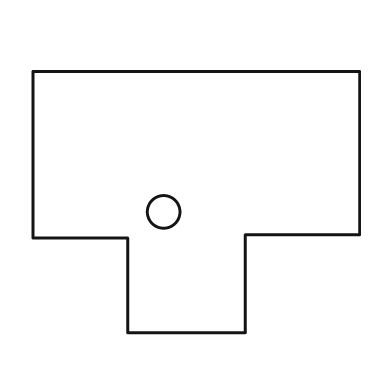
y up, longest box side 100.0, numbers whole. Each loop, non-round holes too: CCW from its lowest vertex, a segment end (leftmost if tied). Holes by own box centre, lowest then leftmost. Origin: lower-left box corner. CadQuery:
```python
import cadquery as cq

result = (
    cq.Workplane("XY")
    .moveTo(29.0, 0.0)
    .lineTo(65.0, 0.0)
    .lineTo(65.0, 30.0)
    .lineTo(100.0, 30.0)
    .lineTo(100.0, 80.0)
    .lineTo(0.0, 80.0)
    .lineTo(0.0, 29.0)
    .lineTo(29.0, 29.0)
    .close()
    .moveTo(40.0, 37.0)
    .circle(5.0)
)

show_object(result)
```